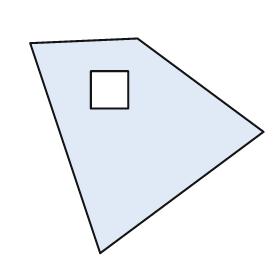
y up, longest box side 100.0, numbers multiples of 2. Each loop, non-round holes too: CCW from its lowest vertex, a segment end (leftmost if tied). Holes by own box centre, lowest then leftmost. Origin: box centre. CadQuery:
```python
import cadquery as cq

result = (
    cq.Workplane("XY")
    .moveTo(-20.0, -46.0)
    .lineTo(50.0, 6.0)
    .lineTo(-4.0, 46.0)
    .lineTo(-50.0, 44.0)
    .close()
    .moveTo(-24.0, 16.0)
    .lineTo(-8.0, 16.0)
    .lineTo(-8.0, 32.0)
    .lineTo(-24.0, 32.0)
    .close()
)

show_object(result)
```